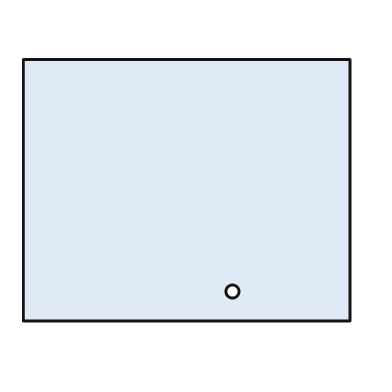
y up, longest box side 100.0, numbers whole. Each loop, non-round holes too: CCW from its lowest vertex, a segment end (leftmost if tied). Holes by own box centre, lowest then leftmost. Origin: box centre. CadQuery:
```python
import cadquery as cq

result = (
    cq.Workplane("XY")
    .moveTo(-50.0, -40.0)
    .lineTo(50.0, -40.0)
    .lineTo(50.0, 40.0)
    .lineTo(-50.0, 40.0)
    .close()
    .moveTo(14.0, -31.0)
    .circle(2.0)
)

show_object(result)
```